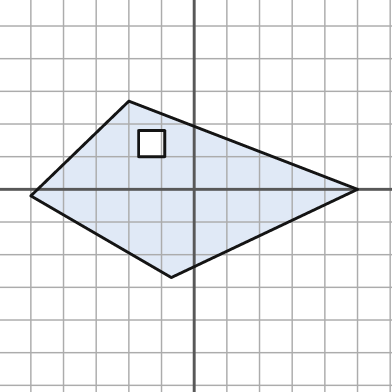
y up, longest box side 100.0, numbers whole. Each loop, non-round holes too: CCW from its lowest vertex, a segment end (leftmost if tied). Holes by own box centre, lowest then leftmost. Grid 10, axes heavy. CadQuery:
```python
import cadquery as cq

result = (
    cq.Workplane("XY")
    .moveTo(-7.0, -27.0)
    .lineTo(50.0, 0.0)
    .lineTo(-20.0, 27.0)
    .lineTo(-50.0, -2.0)
    .close()
    .moveTo(-17.0, 10.0)
    .lineTo(-9.0, 10.0)
    .lineTo(-9.0, 18.0)
    .lineTo(-17.0, 18.0)
    .close()
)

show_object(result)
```